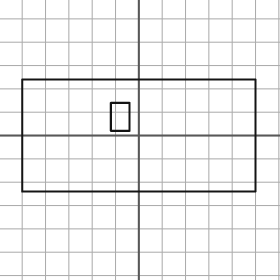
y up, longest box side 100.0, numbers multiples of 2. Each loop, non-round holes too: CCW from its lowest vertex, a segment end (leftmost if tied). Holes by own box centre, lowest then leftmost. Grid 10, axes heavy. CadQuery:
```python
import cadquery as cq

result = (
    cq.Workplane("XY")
    .moveTo(-50.0, -24.0)
    .lineTo(50.0, -24.0)
    .lineTo(50.0, 24.0)
    .lineTo(-50.0, 24.0)
    .close()
    .moveTo(-12.0, 2.0)
    .lineTo(-4.0, 2.0)
    .lineTo(-4.0, 14.0)
    .lineTo(-12.0, 14.0)
    .close()
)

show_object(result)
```